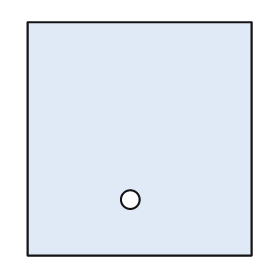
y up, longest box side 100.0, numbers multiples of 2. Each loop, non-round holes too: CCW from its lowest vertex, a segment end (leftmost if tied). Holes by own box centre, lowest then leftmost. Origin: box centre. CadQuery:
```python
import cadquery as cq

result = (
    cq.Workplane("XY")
    .moveTo(-48.0, -50.0)
    .lineTo(48.0, -50.0)
    .lineTo(48.0, 50.0)
    .lineTo(-48.0, 50.0)
    .close()
    .moveTo(-4.0, -26.0)
    .circle(4.0)
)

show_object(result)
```